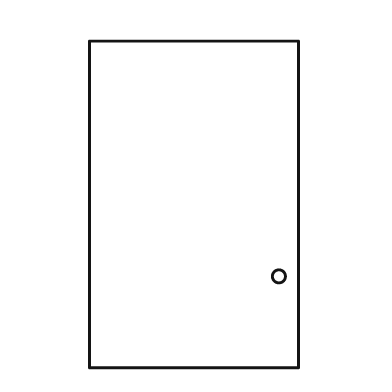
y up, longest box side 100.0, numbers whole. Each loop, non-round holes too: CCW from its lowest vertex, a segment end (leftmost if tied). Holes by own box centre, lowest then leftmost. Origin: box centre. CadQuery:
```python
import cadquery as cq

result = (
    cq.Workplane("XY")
    .moveTo(-32.0, -50.0)
    .lineTo(32.0, -50.0)
    .lineTo(32.0, 50.0)
    .lineTo(-32.0, 50.0)
    .close()
    .moveTo(26.0, -22.0)
    .circle(2.0)
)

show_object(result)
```